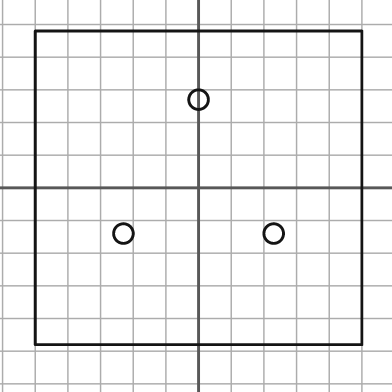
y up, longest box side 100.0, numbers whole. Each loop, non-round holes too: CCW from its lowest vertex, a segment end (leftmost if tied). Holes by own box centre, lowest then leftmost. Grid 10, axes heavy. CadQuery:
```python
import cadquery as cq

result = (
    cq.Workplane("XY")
    .moveTo(-50.0, -48.0)
    .lineTo(50.0, -48.0)
    .lineTo(50.0, 48.0)
    .lineTo(-50.0, 48.0)
    .close()
    .moveTo(-23.0, -14.0)
    .circle(3.0)
    .moveTo(23.0, -14.0)
    .circle(3.0)
    .moveTo(0.0, 27.0)
    .circle(3.0)
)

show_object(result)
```